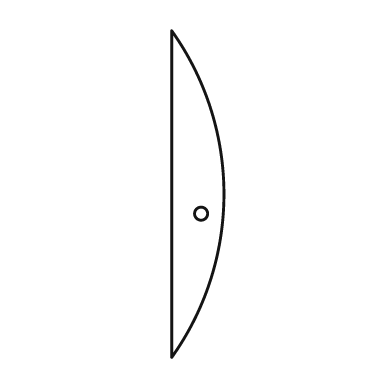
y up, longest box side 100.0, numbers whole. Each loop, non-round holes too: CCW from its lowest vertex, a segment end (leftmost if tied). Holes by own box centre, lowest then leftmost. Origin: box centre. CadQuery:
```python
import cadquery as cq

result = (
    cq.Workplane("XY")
    .moveTo(-8.0, -50.0)
    .threePointArc((8.0, 0.0), (-8.0, 50.0))
    .close()
    .moveTo(1.0, -6.0)
    .circle(2.0)
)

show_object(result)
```